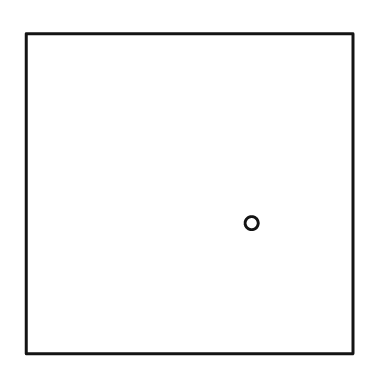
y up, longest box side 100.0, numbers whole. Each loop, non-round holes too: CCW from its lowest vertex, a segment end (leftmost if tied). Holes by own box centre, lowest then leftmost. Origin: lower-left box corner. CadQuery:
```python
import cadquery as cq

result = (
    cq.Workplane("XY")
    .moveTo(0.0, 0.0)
    .lineTo(100.0, 0.0)
    .lineTo(100.0, 98.0)
    .lineTo(0.0, 98.0)
    .close()
    .moveTo(69.0, 40.0)
    .circle(2.0)
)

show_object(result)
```